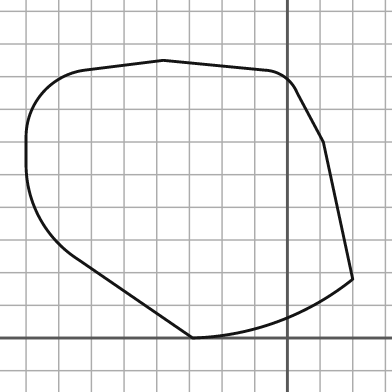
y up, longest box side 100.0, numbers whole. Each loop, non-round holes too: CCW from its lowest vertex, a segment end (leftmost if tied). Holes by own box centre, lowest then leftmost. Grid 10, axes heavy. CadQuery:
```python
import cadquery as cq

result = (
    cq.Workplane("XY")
    .moveTo(-29.0, 0.0)
    .threePointArc((-3.0, 5.0), (20.0, 18.0))
    .lineTo(11.0, 60.0)
    .lineTo(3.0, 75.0)
    .threePointArc((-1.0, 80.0), (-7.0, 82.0))
    .lineTo(-38.0, 85.0)
    .lineTo(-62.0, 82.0)
    .threePointArc((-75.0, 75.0), (-80.0, 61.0))
    .lineTo(-80.0, 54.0)
    .threePointArc((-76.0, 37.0), (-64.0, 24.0))
    .close()
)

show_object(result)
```